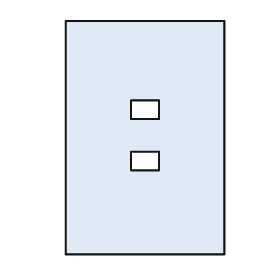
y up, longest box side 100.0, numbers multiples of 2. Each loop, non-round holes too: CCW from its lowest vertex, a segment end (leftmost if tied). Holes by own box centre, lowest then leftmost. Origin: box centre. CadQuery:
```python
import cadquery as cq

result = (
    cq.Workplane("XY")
    .moveTo(-34.0, -50.0)
    .lineTo(34.0, -50.0)
    .lineTo(34.0, 50.0)
    .lineTo(-34.0, 50.0)
    .close()
    .moveTo(-6.0, -14.0)
    .lineTo(6.0, -14.0)
    .lineTo(6.0, -6.0)
    .lineTo(-6.0, -6.0)
    .close()
    .moveTo(-6.0, 8.0)
    .lineTo(6.0, 8.0)
    .lineTo(6.0, 16.0)
    .lineTo(-6.0, 16.0)
    .close()
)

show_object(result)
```